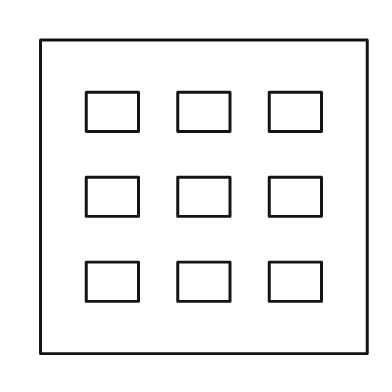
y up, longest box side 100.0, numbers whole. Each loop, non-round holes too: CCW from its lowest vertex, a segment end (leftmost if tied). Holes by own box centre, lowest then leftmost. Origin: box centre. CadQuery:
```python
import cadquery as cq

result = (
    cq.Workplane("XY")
    .moveTo(-50.0, -48.0)
    .lineTo(50.0, -48.0)
    .lineTo(50.0, 48.0)
    .lineTo(-50.0, 48.0)
    .close()
    .moveTo(-36.0, -32.0)
    .lineTo(-20.0, -32.0)
    .lineTo(-20.0, -20.0)
    .lineTo(-36.0, -20.0)
    .close()
    .moveTo(-8.0, -32.0)
    .lineTo(8.0, -32.0)
    .lineTo(8.0, -20.0)
    .lineTo(-8.0, -20.0)
    .close()
    .moveTo(20.0, -32.0)
    .lineTo(36.0, -32.0)
    .lineTo(36.0, -20.0)
    .lineTo(20.0, -20.0)
    .close()
    .moveTo(-36.0, -6.0)
    .lineTo(-20.0, -6.0)
    .lineTo(-20.0, 6.0)
    .lineTo(-36.0, 6.0)
    .close()
    .moveTo(-8.0, -6.0)
    .lineTo(8.0, -6.0)
    .lineTo(8.0, 6.0)
    .lineTo(-8.0, 6.0)
    .close()
    .moveTo(20.0, -6.0)
    .lineTo(36.0, -6.0)
    .lineTo(36.0, 6.0)
    .lineTo(20.0, 6.0)
    .close()
    .moveTo(-36.0, 20.0)
    .lineTo(-20.0, 20.0)
    .lineTo(-20.0, 32.0)
    .lineTo(-36.0, 32.0)
    .close()
    .moveTo(-8.0, 20.0)
    .lineTo(8.0, 20.0)
    .lineTo(8.0, 32.0)
    .lineTo(-8.0, 32.0)
    .close()
    .moveTo(20.0, 20.0)
    .lineTo(36.0, 20.0)
    .lineTo(36.0, 32.0)
    .lineTo(20.0, 32.0)
    .close()
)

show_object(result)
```